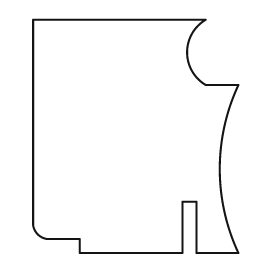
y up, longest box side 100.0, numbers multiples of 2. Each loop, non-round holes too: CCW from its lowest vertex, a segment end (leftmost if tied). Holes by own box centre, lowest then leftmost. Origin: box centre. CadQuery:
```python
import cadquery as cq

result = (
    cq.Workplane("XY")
    .moveTo(-24.0, -50.0)
    .lineTo(20.0, -50.0)
    .lineTo(20.0, -28.0)
    .lineTo(26.0, -28.0)
    .lineTo(26.0, -50.0)
    .lineTo(44.0, -50.0)
    .threePointArc((36.0, -14.0), (44.0, 22.0))
    .lineTo(30.0, 22.0)
    .threePointArc((22.0, 36.0), (30.0, 50.0))
    .lineTo(-44.0, 50.0)
    .lineTo(-44.0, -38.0)
    .threePointArc((-42.0, -42.0), (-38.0, -44.0))
    .lineTo(-24.0, -44.0)
    .close()
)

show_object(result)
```